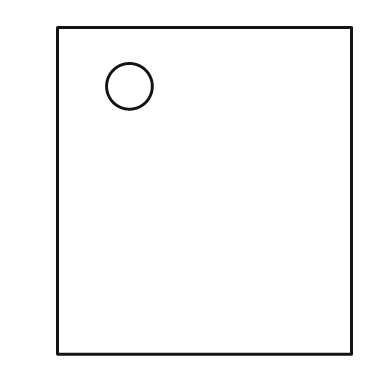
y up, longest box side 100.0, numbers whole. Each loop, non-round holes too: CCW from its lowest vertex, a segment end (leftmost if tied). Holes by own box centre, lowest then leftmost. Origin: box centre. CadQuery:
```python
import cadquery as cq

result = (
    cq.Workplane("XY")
    .moveTo(-45.0, -50.0)
    .lineTo(45.0, -50.0)
    .lineTo(45.0, 50.0)
    .lineTo(-45.0, 50.0)
    .close()
    .moveTo(-23.0, 32.0)
    .circle(7.0)
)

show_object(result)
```